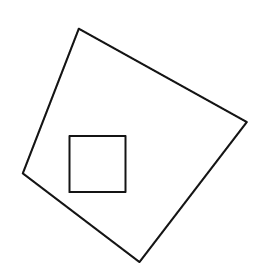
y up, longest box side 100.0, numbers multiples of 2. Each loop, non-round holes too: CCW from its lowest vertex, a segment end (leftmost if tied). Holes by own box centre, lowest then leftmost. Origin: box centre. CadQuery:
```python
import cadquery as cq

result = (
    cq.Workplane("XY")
    .moveTo(2.0, -50.0)
    .lineTo(48.0, 10.0)
    .lineTo(-24.0, 50.0)
    .lineTo(-48.0, -12.0)
    .close()
    .moveTo(-28.0, -20.0)
    .lineTo(-4.0, -20.0)
    .lineTo(-4.0, 4.0)
    .lineTo(-28.0, 4.0)
    .close()
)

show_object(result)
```